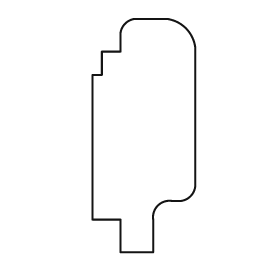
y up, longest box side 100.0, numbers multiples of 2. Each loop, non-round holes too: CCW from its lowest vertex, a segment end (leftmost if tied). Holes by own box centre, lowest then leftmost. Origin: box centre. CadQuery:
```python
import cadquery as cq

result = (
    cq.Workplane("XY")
    .moveTo(-10.0, -50.0)
    .lineTo(4.0, -50.0)
    .lineTo(4.0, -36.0)
    .threePointArc((6.0, -30.0), (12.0, -28.0))
    .lineTo(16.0, -28.0)
    .threePointArc((20.0, -26.0), (22.0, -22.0))
    .lineTo(22.0, 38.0)
    .threePointArc((18.0, 46.0), (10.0, 50.0))
    .lineTo(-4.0, 50.0)
    .threePointArc((-8.0, 48.0), (-10.0, 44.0))
    .lineTo(-10.0, 36.0)
    .lineTo(-18.0, 36.0)
    .lineTo(-18.0, 26.0)
    .lineTo(-22.0, 26.0)
    .lineTo(-22.0, -36.0)
    .lineTo(-10.0, -36.0)
    .close()
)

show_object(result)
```